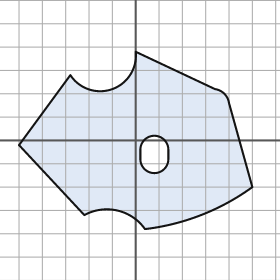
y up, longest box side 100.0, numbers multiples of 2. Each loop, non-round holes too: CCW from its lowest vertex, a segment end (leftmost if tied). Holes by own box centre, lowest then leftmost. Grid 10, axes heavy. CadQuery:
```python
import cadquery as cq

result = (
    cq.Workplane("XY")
    .moveTo(4.0, -38.0)
    .threePointArc((28.0, -32.0), (50.0, -20.0))
    .lineTo(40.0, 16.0)
    .threePointArc((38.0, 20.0), (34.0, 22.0))
    .lineTo(0.0, 38.0)
    .threePointArc((-10.0, 22.0), (-28.0, 28.0))
    .lineTo(-50.0, -2.0)
    .lineTo(-22.0, -32.0)
    .threePointArc((-8.0, -30.0), (4.0, -38.0))
    .close()
    .moveTo(2.0, -8.0)
    .threePointArc((8.0, -14.0), (14.0, -8.0))
    .lineTo(14.0, -4.0)
    .threePointArc((8.0, 2.0), (2.0, -4.0))
    .close()
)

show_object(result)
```